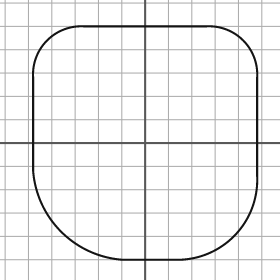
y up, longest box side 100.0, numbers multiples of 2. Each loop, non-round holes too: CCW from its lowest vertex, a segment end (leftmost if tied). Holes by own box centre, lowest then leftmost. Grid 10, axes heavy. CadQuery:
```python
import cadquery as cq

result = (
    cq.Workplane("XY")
    .moveTo(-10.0, -50.0)
    .lineTo(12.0, -50.0)
    .threePointArc((38.0, -40.0), (48.0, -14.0))
    .lineTo(48.0, 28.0)
    .threePointArc((42.0, 44.0), (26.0, 50.0))
    .lineTo(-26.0, 50.0)
    .threePointArc((-42.0, 44.0), (-48.0, 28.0))
    .lineTo(-48.0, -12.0)
    .threePointArc((-36.0, -38.0), (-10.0, -50.0))
    .close()
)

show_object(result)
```